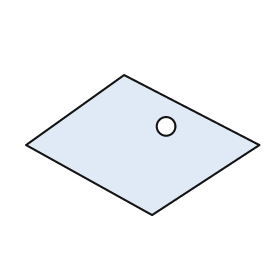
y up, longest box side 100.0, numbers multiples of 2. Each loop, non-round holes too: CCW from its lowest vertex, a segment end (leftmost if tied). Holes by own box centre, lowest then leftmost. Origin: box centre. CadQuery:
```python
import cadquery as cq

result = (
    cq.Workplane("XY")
    .moveTo(4.0, -30.0)
    .lineTo(50.0, 0.0)
    .lineTo(-8.0, 30.0)
    .lineTo(-50.0, 0.0)
    .close()
    .moveTo(10.0, 8.0)
    .circle(4.0)
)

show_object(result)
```